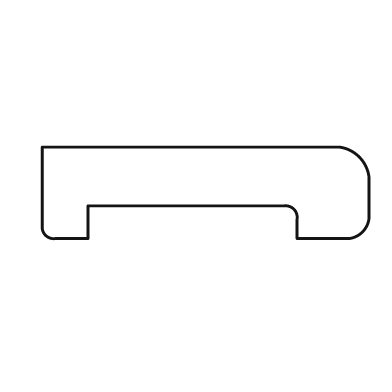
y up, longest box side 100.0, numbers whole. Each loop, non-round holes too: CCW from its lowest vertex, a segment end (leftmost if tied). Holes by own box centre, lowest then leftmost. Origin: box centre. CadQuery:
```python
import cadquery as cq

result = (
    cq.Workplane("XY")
    .moveTo(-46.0, -14.0)
    .lineTo(-36.0, -14.0)
    .lineTo(-36.0, -4.0)
    .lineTo(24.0, -4.0)
    .threePointArc((27.0, -5.0), (28.0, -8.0))
    .lineTo(28.0, -14.0)
    .lineTo(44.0, -14.0)
    .threePointArc((48.0, -12.0), (50.0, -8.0))
    .lineTo(50.0, 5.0)
    .threePointArc((47.0, 11.0), (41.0, 14.0))
    .lineTo(-50.0, 14.0)
    .lineTo(-50.0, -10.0)
    .threePointArc((-49.0, -13.0), (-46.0, -14.0))
    .close()
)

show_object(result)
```